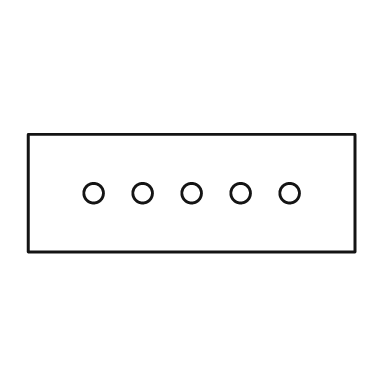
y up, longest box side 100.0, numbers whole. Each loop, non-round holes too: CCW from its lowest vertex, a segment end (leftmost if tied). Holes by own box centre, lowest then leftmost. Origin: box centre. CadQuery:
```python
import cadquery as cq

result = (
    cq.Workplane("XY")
    .moveTo(-50.0, -18.0)
    .lineTo(50.0, -18.0)
    .lineTo(50.0, 18.0)
    .lineTo(-50.0, 18.0)
    .close()
    .moveTo(-30.0, 0.0)
    .circle(3.0)
    .moveTo(-15.0, 0.0)
    .circle(3.0)
    .moveTo(0.0, 0.0)
    .circle(3.0)
    .moveTo(15.0, 0.0)
    .circle(3.0)
    .moveTo(30.0, 0.0)
    .circle(3.0)
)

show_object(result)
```